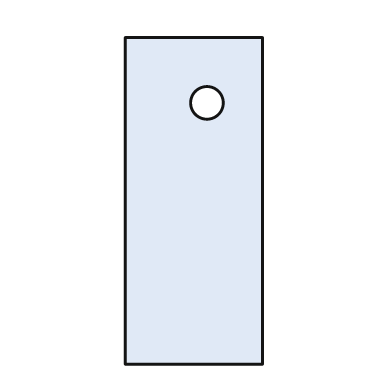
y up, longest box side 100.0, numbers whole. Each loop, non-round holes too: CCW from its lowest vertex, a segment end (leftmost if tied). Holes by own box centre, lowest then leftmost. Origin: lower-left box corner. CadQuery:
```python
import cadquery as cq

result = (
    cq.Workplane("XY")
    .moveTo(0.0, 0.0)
    .lineTo(42.0, 0.0)
    .lineTo(42.0, 100.0)
    .lineTo(0.0, 100.0)
    .close()
    .moveTo(25.0, 80.0)
    .circle(5.0)
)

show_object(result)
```